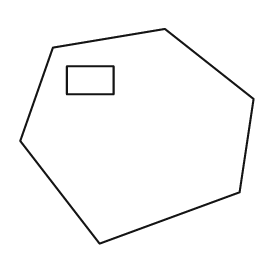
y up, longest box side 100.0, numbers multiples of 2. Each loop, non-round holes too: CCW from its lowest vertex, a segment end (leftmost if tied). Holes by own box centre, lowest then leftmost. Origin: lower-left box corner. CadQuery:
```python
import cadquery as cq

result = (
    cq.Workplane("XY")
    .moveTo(34.0, 0.0)
    .lineTo(94.0, 22.0)
    .lineTo(100.0, 62.0)
    .lineTo(62.0, 92.0)
    .lineTo(14.0, 84.0)
    .lineTo(0.0, 44.0)
    .close()
    .moveTo(20.0, 64.0)
    .lineTo(40.0, 64.0)
    .lineTo(40.0, 76.0)
    .lineTo(20.0, 76.0)
    .close()
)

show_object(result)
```